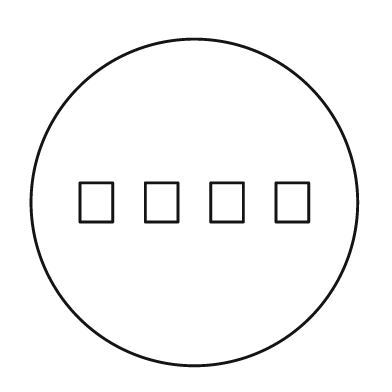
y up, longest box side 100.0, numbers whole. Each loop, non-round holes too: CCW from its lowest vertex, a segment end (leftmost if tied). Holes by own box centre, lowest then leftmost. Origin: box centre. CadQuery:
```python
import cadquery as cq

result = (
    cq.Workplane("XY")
    .moveTo(0.0, 0.0)
    .circle(50.0)
    .moveTo(-35.0, -6.0)
    .lineTo(-25.0, -6.0)
    .lineTo(-25.0, 6.0)
    .lineTo(-35.0, 6.0)
    .close()
    .moveTo(-15.0, -6.0)
    .lineTo(-5.0, -6.0)
    .lineTo(-5.0, 6.0)
    .lineTo(-15.0, 6.0)
    .close()
    .moveTo(5.0, -6.0)
    .lineTo(15.0, -6.0)
    .lineTo(15.0, 6.0)
    .lineTo(5.0, 6.0)
    .close()
    .moveTo(25.0, -6.0)
    .lineTo(35.0, -6.0)
    .lineTo(35.0, 6.0)
    .lineTo(25.0, 6.0)
    .close()
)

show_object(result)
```